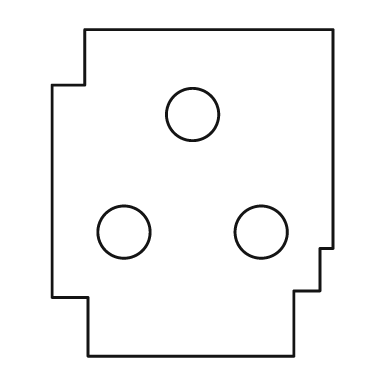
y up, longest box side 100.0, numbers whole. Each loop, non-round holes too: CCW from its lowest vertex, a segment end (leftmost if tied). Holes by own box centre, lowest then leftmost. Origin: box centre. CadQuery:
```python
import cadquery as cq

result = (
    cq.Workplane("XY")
    .moveTo(-32.0, -50.0)
    .lineTo(31.0, -50.0)
    .lineTo(31.0, -30.0)
    .lineTo(39.0, -30.0)
    .lineTo(39.0, -17.0)
    .lineTo(43.0, -17.0)
    .lineTo(43.0, 50.0)
    .lineTo(-33.0, 50.0)
    .lineTo(-33.0, 33.0)
    .lineTo(-43.0, 33.0)
    .lineTo(-43.0, -32.0)
    .lineTo(-32.0, -32.0)
    .close()
    .moveTo(-21.0, -12.0)
    .circle(8.0)
    .moveTo(21.0, -12.0)
    .circle(8.0)
    .moveTo(0.0, 24.0)
    .circle(8.0)
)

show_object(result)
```